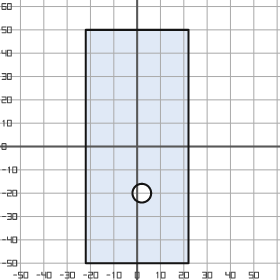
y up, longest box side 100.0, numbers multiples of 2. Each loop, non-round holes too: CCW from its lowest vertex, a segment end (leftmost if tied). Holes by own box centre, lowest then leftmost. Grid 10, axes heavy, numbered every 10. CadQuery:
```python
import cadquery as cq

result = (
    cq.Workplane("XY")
    .moveTo(-22.0, -50.0)
    .lineTo(22.0, -50.0)
    .lineTo(22.0, 50.0)
    .lineTo(-22.0, 50.0)
    .close()
    .moveTo(2.0, -20.0)
    .circle(4.0)
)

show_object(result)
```